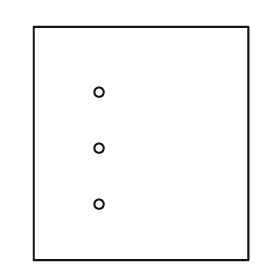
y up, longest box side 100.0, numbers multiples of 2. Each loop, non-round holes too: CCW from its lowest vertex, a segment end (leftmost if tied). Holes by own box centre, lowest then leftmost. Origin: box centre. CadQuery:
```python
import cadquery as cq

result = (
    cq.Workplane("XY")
    .moveTo(-46.0, -50.0)
    .lineTo(46.0, -50.0)
    .lineTo(46.0, 50.0)
    .lineTo(-46.0, 50.0)
    .close()
    .moveTo(-18.0, -26.0)
    .circle(2.0)
    .moveTo(-18.0, -2.0)
    .circle(2.0)
    .moveTo(-18.0, 22.0)
    .circle(2.0)
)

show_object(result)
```